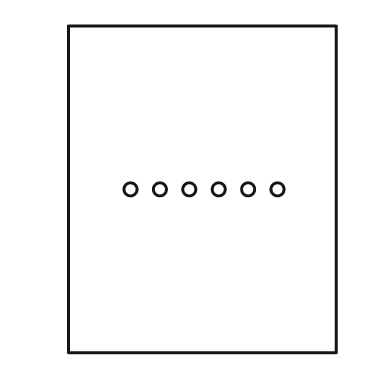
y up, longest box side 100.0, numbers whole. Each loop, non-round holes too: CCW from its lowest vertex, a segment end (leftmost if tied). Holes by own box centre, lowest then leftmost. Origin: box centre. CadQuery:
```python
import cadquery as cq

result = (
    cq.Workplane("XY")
    .moveTo(-41.0, -50.0)
    .lineTo(41.0, -50.0)
    .lineTo(41.0, 50.0)
    .lineTo(-41.0, 50.0)
    .close()
    .moveTo(-22.0, 0.0)
    .circle(2.0)
    .moveTo(-13.0, 0.0)
    .circle(2.0)
    .moveTo(-4.0, 0.0)
    .circle(2.0)
    .moveTo(5.0, 0.0)
    .circle(2.0)
    .moveTo(14.0, 0.0)
    .circle(2.0)
    .moveTo(23.0, 0.0)
    .circle(2.0)
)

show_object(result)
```